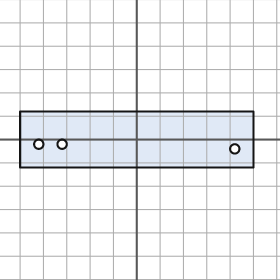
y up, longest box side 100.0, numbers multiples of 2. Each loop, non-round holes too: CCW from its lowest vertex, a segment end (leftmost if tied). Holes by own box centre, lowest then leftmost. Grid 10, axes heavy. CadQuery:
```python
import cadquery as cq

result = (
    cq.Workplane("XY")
    .moveTo(-50.0, -12.0)
    .lineTo(50.0, -12.0)
    .lineTo(50.0, 12.0)
    .lineTo(-50.0, 12.0)
    .close()
    .moveTo(42.0, -4.0)
    .circle(2.0)
    .moveTo(-42.0, -2.0)
    .circle(2.0)
    .moveTo(-32.0, -2.0)
    .circle(2.0)
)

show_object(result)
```